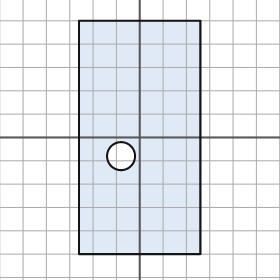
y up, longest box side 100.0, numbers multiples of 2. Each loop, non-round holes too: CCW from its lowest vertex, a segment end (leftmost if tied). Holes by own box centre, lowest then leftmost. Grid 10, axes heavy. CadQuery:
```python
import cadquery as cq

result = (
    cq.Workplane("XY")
    .moveTo(-26.0, -50.0)
    .lineTo(26.0, -50.0)
    .lineTo(26.0, 50.0)
    .lineTo(-26.0, 50.0)
    .close()
    .moveTo(-8.0, -8.0)
    .circle(6.0)
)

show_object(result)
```